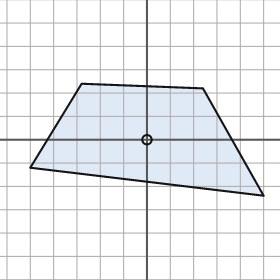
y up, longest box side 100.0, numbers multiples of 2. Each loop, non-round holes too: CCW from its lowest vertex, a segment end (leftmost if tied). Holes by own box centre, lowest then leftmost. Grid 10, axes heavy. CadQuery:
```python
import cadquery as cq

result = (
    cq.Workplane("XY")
    .moveTo(50.0, -24.0)
    .lineTo(24.0, 22.0)
    .lineTo(-28.0, 24.0)
    .lineTo(-50.0, -12.0)
    .close()
    .moveTo(0.0, 0.0)
    .circle(2.0)
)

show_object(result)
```